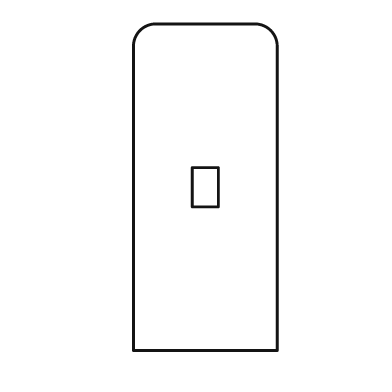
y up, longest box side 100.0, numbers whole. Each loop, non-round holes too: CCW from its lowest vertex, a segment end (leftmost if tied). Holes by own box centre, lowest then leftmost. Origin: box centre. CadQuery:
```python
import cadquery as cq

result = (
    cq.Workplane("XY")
    .moveTo(-22.0, -50.0)
    .lineTo(22.0, -50.0)
    .lineTo(22.0, 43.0)
    .threePointArc((20.0, 48.0), (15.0, 50.0))
    .lineTo(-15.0, 50.0)
    .threePointArc((-20.0, 48.0), (-22.0, 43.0))
    .close()
    .moveTo(-4.0, -6.0)
    .lineTo(4.0, -6.0)
    .lineTo(4.0, 6.0)
    .lineTo(-4.0, 6.0)
    .close()
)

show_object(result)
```